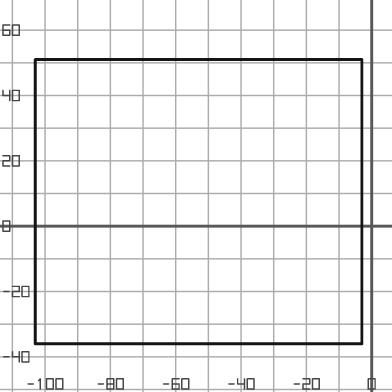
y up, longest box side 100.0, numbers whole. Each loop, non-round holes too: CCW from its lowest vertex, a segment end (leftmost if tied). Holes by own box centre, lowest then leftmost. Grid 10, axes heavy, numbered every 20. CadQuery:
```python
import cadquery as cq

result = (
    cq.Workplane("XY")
    .moveTo(-103.0, -36.0)
    .lineTo(-3.0, -36.0)
    .lineTo(-3.0, 51.0)
    .lineTo(-103.0, 51.0)
    .close()
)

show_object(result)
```